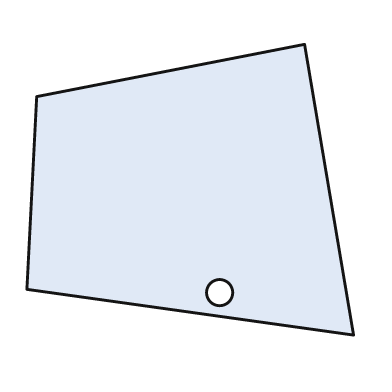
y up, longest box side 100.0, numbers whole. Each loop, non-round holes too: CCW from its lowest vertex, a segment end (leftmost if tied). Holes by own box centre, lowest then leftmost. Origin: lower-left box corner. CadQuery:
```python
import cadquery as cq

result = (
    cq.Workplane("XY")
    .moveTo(100.0, 0.0)
    .lineTo(85.0, 89.0)
    .lineTo(3.0, 73.0)
    .lineTo(0.0, 14.0)
    .close()
    .moveTo(59.0, 13.0)
    .circle(4.0)
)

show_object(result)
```